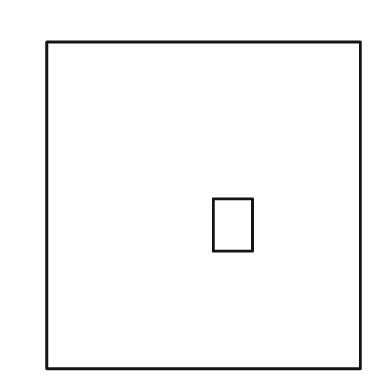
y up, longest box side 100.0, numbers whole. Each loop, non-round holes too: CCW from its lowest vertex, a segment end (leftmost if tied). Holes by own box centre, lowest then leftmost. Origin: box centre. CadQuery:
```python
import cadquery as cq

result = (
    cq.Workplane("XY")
    .moveTo(-48.0, -50.0)
    .lineTo(48.0, -50.0)
    .lineTo(48.0, 50.0)
    .lineTo(-48.0, 50.0)
    .close()
    .moveTo(3.0, -14.0)
    .lineTo(15.0, -14.0)
    .lineTo(15.0, 2.0)
    .lineTo(3.0, 2.0)
    .close()
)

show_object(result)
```